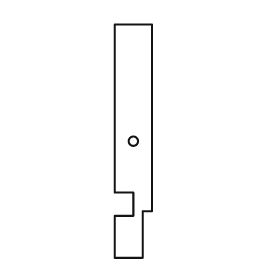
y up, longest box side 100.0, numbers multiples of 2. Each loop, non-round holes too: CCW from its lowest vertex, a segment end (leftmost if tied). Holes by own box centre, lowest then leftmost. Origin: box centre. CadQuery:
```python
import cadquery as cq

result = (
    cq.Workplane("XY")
    .moveTo(-8.0, -50.0)
    .lineTo(4.0, -50.0)
    .lineTo(4.0, -30.0)
    .lineTo(8.0, -30.0)
    .lineTo(8.0, 50.0)
    .lineTo(-8.0, 50.0)
    .lineTo(-8.0, -22.0)
    .lineTo(0.0, -22.0)
    .lineTo(0.0, -32.0)
    .lineTo(-8.0, -32.0)
    .close()
    .moveTo(0.0, 0.0)
    .circle(2.0)
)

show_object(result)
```